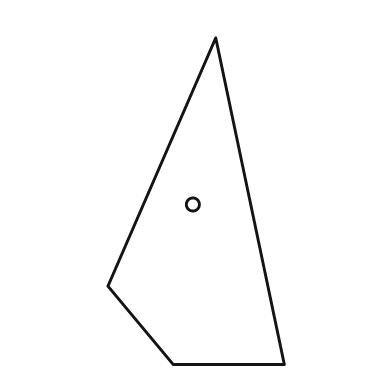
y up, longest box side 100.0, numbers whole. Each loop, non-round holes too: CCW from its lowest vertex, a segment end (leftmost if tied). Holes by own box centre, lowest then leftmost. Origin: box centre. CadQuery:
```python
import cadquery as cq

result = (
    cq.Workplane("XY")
    .moveTo(-7.0, -50.0)
    .lineTo(27.0, -50.0)
    .lineTo(6.0, 50.0)
    .lineTo(-27.0, -26.0)
    .close()
    .moveTo(-1.0, -1.0)
    .circle(2.0)
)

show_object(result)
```